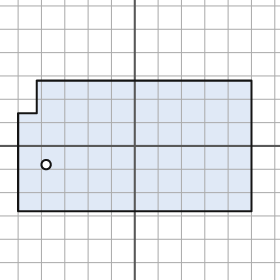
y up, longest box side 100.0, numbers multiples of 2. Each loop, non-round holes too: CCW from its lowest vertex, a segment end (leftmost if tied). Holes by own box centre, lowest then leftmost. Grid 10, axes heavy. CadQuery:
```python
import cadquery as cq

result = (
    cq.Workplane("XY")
    .moveTo(-50.0, -28.0)
    .lineTo(50.0, -28.0)
    .lineTo(50.0, 28.0)
    .lineTo(-42.0, 28.0)
    .lineTo(-42.0, 14.0)
    .lineTo(-50.0, 14.0)
    .close()
    .moveTo(-38.0, -8.0)
    .circle(2.0)
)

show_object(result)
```